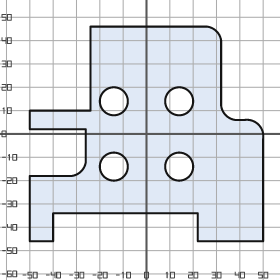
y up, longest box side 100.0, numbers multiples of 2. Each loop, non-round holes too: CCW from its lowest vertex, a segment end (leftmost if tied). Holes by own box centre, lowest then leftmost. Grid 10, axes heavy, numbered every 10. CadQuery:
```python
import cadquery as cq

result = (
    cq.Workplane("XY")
    .moveTo(-50.0, -46.0)
    .lineTo(-40.0, -46.0)
    .lineTo(-40.0, -34.0)
    .lineTo(22.0, -34.0)
    .lineTo(22.0, -46.0)
    .lineTo(50.0, -46.0)
    .lineTo(50.0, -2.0)
    .threePointArc((48.0, 4.0), (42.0, 6.0))
    .lineTo(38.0, 6.0)
    .threePointArc((34.0, 8.0), (32.0, 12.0))
    .lineTo(32.0, 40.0)
    .threePointArc((30.0, 44.0), (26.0, 46.0))
    .lineTo(-24.0, 46.0)
    .lineTo(-24.0, 10.0)
    .lineTo(-50.0, 10.0)
    .lineTo(-50.0, 2.0)
    .lineTo(-26.0, 2.0)
    .lineTo(-26.0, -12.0)
    .threePointArc((-28.0, -16.0), (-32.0, -18.0))
    .lineTo(-50.0, -18.0)
    .close()
    .moveTo(-14.0, -14.0)
    .circle(6.0)
    .moveTo(14.0, -14.0)
    .circle(6.0)
    .moveTo(-14.0, 14.0)
    .circle(6.0)
    .moveTo(14.0, 14.0)
    .circle(6.0)
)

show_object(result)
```